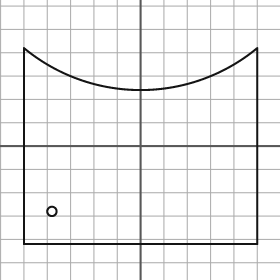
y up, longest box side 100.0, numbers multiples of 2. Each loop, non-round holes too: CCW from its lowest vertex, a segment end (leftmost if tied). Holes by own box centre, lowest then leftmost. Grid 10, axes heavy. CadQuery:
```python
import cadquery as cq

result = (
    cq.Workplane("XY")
    .moveTo(-50.0, -42.0)
    .lineTo(50.0, -42.0)
    .lineTo(50.0, 42.0)
    .threePointArc((0.0, 24.0), (-50.0, 42.0))
    .close()
    .moveTo(-38.0, -28.0)
    .circle(2.0)
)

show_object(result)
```